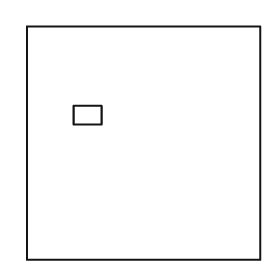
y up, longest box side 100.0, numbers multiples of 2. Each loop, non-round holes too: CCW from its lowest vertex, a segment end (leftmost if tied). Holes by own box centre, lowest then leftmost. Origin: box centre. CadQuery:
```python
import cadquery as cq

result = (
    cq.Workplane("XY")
    .moveTo(-50.0, -50.0)
    .lineTo(50.0, -50.0)
    .lineTo(50.0, 50.0)
    .lineTo(-50.0, 50.0)
    .close()
    .moveTo(-30.0, 8.0)
    .lineTo(-18.0, 8.0)
    .lineTo(-18.0, 16.0)
    .lineTo(-30.0, 16.0)
    .close()
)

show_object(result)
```